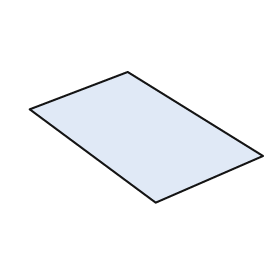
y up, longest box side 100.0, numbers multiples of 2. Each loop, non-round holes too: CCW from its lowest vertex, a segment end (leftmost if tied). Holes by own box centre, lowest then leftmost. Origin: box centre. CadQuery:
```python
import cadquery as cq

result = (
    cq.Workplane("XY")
    .moveTo(4.0, -28.0)
    .lineTo(50.0, -8.0)
    .lineTo(-8.0, 28.0)
    .lineTo(-50.0, 12.0)
    .close()
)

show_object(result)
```